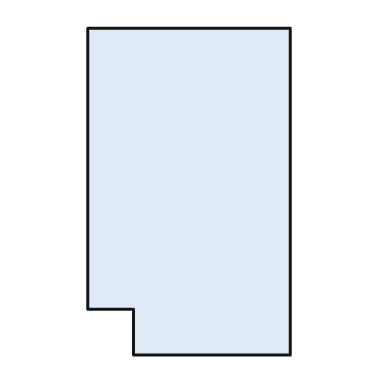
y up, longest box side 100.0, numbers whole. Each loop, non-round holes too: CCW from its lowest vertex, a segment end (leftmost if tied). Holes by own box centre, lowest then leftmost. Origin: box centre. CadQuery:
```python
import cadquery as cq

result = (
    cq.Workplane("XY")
    .moveTo(-17.0, -50.0)
    .lineTo(31.0, -50.0)
    .lineTo(31.0, 50.0)
    .lineTo(-31.0, 50.0)
    .lineTo(-31.0, -36.0)
    .lineTo(-17.0, -36.0)
    .close()
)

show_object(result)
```